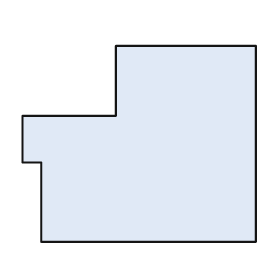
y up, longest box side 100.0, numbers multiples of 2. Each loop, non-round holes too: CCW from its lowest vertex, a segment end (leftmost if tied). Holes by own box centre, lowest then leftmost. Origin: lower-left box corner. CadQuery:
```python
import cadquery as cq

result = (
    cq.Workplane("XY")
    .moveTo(8.0, 0.0)
    .lineTo(100.0, 0.0)
    .lineTo(100.0, 84.0)
    .lineTo(40.0, 84.0)
    .lineTo(40.0, 54.0)
    .lineTo(0.0, 54.0)
    .lineTo(0.0, 34.0)
    .lineTo(8.0, 34.0)
    .close()
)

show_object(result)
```